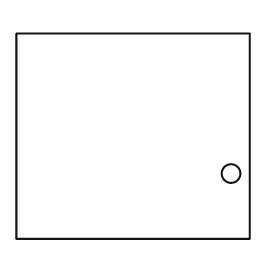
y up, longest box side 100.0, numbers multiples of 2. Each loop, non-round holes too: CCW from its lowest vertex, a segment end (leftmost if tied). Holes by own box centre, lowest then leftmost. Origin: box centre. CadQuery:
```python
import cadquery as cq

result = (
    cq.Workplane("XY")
    .moveTo(-50.0, -44.0)
    .lineTo(50.0, -44.0)
    .lineTo(50.0, 44.0)
    .lineTo(-50.0, 44.0)
    .close()
    .moveTo(42.0, -16.0)
    .circle(4.0)
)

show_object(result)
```